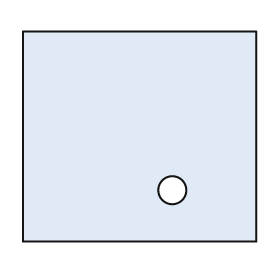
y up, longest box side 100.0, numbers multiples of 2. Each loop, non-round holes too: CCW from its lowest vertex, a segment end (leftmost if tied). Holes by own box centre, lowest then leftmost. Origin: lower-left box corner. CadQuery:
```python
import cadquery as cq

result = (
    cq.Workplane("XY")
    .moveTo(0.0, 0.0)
    .lineTo(100.0, 0.0)
    .lineTo(100.0, 90.0)
    .lineTo(0.0, 90.0)
    .close()
    .moveTo(64.0, 22.0)
    .circle(6.0)
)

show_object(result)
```